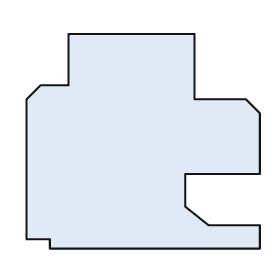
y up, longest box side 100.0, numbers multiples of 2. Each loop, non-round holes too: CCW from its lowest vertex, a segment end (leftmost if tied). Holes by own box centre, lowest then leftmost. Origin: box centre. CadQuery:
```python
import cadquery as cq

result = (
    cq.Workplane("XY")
    .moveTo(-40.0, -46.0)
    .lineTo(50.0, -46.0)
    .lineTo(50.0, -36.0)
    .lineTo(28.0, -36.0)
    .lineTo(18.0, -28.0)
    .lineTo(18.0, -14.0)
    .lineTo(50.0, -14.0)
    .lineTo(50.0, 12.0)
    .lineTo(44.0, 18.0)
    .lineTo(22.0, 18.0)
    .lineTo(22.0, 46.0)
    .lineTo(-32.0, 46.0)
    .lineTo(-32.0, 24.0)
    .lineTo(-44.0, 24.0)
    .lineTo(-50.0, 18.0)
    .lineTo(-50.0, -42.0)
    .lineTo(-40.0, -42.0)
    .close()
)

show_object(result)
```